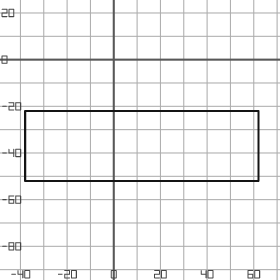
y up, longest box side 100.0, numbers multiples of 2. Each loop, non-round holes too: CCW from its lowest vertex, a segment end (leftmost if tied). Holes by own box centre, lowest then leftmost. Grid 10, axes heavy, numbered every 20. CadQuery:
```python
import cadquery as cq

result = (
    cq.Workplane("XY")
    .moveTo(-38.0, -52.0)
    .lineTo(62.0, -52.0)
    .lineTo(62.0, -22.0)
    .lineTo(-38.0, -22.0)
    .close()
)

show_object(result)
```